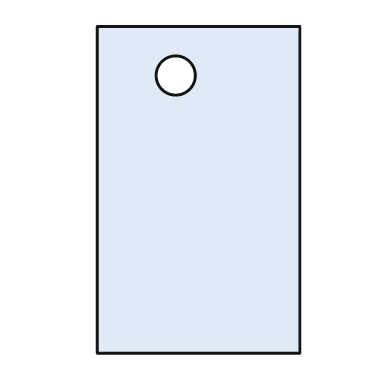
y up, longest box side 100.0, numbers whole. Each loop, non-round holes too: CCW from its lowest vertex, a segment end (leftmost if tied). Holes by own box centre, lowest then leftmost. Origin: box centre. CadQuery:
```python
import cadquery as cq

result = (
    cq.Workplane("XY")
    .moveTo(-31.0, -50.0)
    .lineTo(31.0, -50.0)
    .lineTo(31.0, 50.0)
    .lineTo(-31.0, 50.0)
    .close()
    .moveTo(-7.0, 35.0)
    .circle(6.0)
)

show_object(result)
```